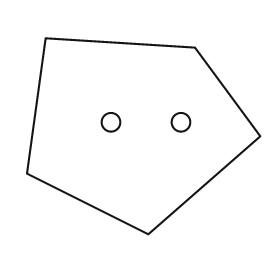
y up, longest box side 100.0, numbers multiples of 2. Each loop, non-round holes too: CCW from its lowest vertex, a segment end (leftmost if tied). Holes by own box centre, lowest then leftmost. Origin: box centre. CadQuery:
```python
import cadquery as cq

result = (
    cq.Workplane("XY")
    .moveTo(2.0, -42.0)
    .lineTo(50.0, 0.0)
    .lineTo(22.0, 38.0)
    .lineTo(-42.0, 42.0)
    .lineTo(-50.0, -16.0)
    .close()
    .moveTo(-14.0, 6.0)
    .circle(4.0)
    .moveTo(16.0, 6.0)
    .circle(4.0)
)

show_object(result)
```